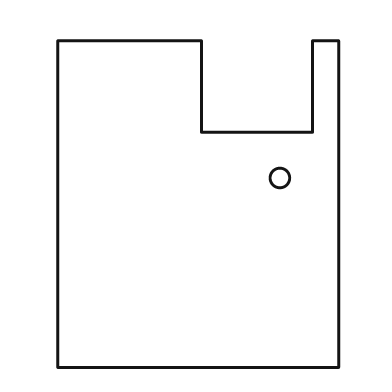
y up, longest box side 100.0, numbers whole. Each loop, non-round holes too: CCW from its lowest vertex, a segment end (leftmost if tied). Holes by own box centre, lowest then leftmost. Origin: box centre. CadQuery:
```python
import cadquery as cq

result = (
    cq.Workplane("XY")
    .moveTo(-43.0, -50.0)
    .lineTo(43.0, -50.0)
    .lineTo(43.0, 50.0)
    .lineTo(35.0, 50.0)
    .lineTo(35.0, 22.0)
    .lineTo(1.0, 22.0)
    .lineTo(1.0, 50.0)
    .lineTo(-43.0, 50.0)
    .close()
    .moveTo(25.0, 8.0)
    .circle(3.0)
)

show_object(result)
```